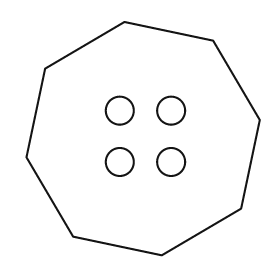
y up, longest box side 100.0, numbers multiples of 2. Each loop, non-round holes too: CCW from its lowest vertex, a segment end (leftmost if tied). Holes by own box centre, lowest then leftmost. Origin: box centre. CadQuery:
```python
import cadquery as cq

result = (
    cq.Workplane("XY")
    .moveTo(8.0, -50.0)
    .lineTo(42.0, -30.0)
    .lineTo(50.0, 8.0)
    .lineTo(30.0, 42.0)
    .lineTo(-8.0, 50.0)
    .lineTo(-42.0, 30.0)
    .lineTo(-50.0, -8.0)
    .lineTo(-30.0, -42.0)
    .close()
    .moveTo(-10.0, -10.0)
    .circle(6.0)
    .moveTo(12.0, -10.0)
    .circle(6.0)
    .moveTo(-10.0, 12.0)
    .circle(6.0)
    .moveTo(12.0, 12.0)
    .circle(6.0)
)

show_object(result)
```